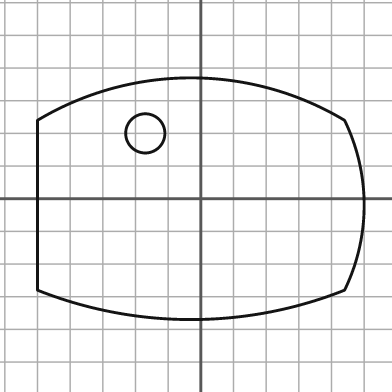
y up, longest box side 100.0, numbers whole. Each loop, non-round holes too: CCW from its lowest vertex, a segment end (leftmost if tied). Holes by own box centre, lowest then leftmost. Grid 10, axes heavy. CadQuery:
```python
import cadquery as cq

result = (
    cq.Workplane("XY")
    .moveTo(-50.0, -28.0)
    .threePointArc((-3.0, -37.0), (44.0, -28.0))
    .threePointArc((50.0, -2.0), (44.0, 24.0))
    .threePointArc((-3.0, 37.0), (-50.0, 24.0))
    .close()
    .moveTo(-17.0, 20.0)
    .circle(6.0)
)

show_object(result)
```